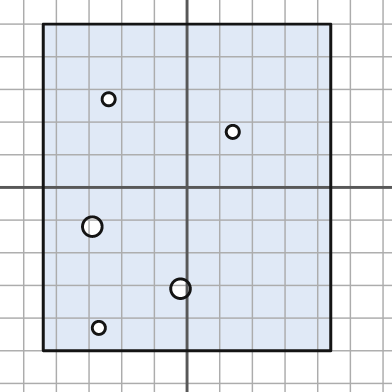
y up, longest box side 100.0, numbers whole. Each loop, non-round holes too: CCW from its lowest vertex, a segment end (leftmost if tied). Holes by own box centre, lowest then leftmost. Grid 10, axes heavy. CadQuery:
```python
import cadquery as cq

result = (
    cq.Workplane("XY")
    .moveTo(-44.0, -50.0)
    .lineTo(44.0, -50.0)
    .lineTo(44.0, 50.0)
    .lineTo(-44.0, 50.0)
    .close()
    .moveTo(-27.0, -43.0)
    .circle(2.0)
    .moveTo(-2.0, -31.0)
    .circle(3.0)
    .moveTo(-29.0, -12.0)
    .circle(3.0)
    .moveTo(14.0, 17.0)
    .circle(2.0)
    .moveTo(-24.0, 27.0)
    .circle(2.0)
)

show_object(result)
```